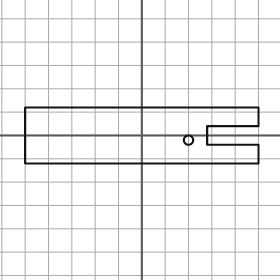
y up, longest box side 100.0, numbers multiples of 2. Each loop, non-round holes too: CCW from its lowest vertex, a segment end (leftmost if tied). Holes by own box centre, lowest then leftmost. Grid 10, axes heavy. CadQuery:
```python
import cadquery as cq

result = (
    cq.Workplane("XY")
    .moveTo(-50.0, -12.0)
    .lineTo(50.0, -12.0)
    .lineTo(50.0, -4.0)
    .lineTo(28.0, -4.0)
    .lineTo(28.0, 4.0)
    .lineTo(50.0, 4.0)
    .lineTo(50.0, 12.0)
    .lineTo(-50.0, 12.0)
    .close()
    .moveTo(20.0, -2.0)
    .circle(2.0)
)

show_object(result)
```